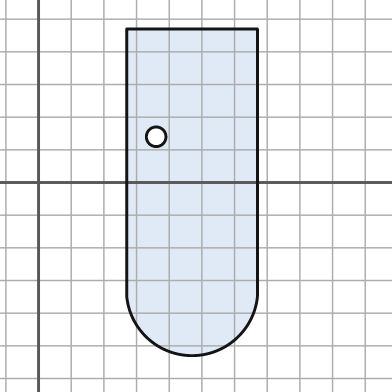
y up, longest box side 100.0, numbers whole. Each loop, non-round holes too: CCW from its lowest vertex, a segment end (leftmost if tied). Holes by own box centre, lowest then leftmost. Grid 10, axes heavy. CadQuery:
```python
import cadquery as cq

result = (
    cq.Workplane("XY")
    .moveTo(27.0, -35.0)
    .threePointArc((47.0, -53.0), (67.0, -35.0))
    .lineTo(67.0, 47.0)
    .lineTo(27.0, 47.0)
    .close()
    .moveTo(36.0, 14.0)
    .circle(3.0)
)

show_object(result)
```